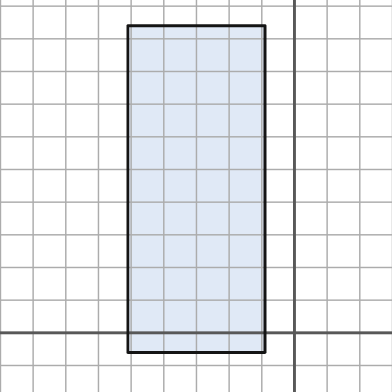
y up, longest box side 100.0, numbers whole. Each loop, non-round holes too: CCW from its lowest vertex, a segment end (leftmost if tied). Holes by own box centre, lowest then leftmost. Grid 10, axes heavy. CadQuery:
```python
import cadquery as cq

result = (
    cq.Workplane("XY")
    .moveTo(-51.0, -6.0)
    .lineTo(-9.0, -6.0)
    .lineTo(-9.0, 94.0)
    .lineTo(-51.0, 94.0)
    .close()
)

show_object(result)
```